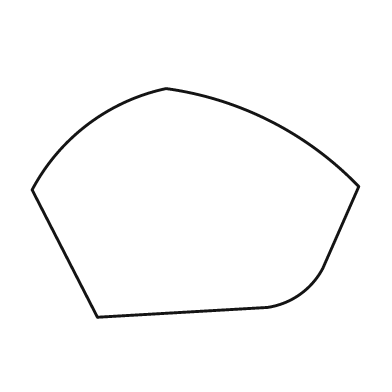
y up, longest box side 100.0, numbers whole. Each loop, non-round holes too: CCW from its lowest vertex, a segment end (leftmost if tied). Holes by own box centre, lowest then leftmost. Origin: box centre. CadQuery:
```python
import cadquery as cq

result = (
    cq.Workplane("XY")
    .moveTo(-30.0, -35.0)
    .lineTo(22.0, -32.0)
    .threePointArc((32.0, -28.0), (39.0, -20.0))
    .lineTo(50.0, 5.0)
    .threePointArc((23.0, 25.0), (-9.0, 35.0))
    .threePointArc((-33.0, 24.0), (-50.0, 4.0))
    .close()
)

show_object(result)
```